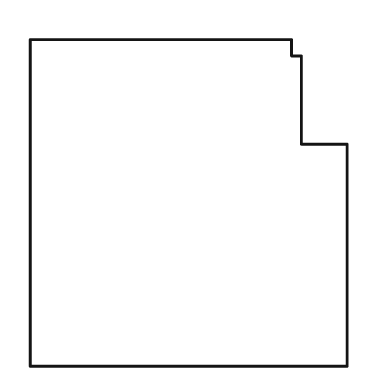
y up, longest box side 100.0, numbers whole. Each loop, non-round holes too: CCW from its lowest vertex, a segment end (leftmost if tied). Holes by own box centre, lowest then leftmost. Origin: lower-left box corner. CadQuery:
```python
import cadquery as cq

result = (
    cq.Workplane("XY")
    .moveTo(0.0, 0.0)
    .lineTo(97.0, 0.0)
    .lineTo(97.0, 68.0)
    .lineTo(83.0, 68.0)
    .lineTo(83.0, 95.0)
    .lineTo(80.0, 95.0)
    .lineTo(80.0, 100.0)
    .lineTo(0.0, 100.0)
    .close()
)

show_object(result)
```